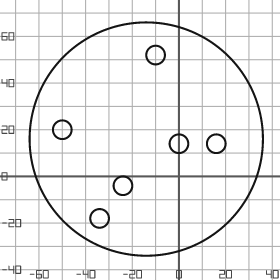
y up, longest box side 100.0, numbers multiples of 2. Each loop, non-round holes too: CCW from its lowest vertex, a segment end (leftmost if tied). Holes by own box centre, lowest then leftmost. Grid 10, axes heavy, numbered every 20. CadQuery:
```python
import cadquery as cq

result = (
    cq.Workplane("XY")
    .moveTo(-14.0, 16.0)
    .circle(50.0)
    .moveTo(-34.0, -18.0)
    .circle(4.0)
    .moveTo(-24.0, -4.0)
    .circle(4.0)
    .moveTo(0.0, 14.0)
    .circle(4.0)
    .moveTo(16.0, 14.0)
    .circle(4.0)
    .moveTo(-50.0, 20.0)
    .circle(4.0)
    .moveTo(-10.0, 52.0)
    .circle(4.0)
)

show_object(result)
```